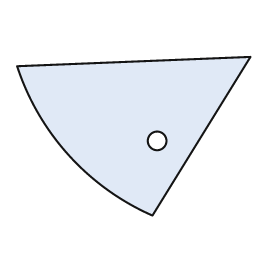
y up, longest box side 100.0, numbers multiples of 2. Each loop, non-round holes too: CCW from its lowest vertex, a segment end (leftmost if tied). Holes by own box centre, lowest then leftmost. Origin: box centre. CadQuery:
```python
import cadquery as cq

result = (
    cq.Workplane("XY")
    .moveTo(8.0, -34.0)
    .lineTo(50.0, 34.0)
    .lineTo(-50.0, 30.0)
    .threePointArc((-28.0, -8.0), (8.0, -34.0))
    .close()
    .moveTo(10.0, -2.0)
    .circle(4.0)
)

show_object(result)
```